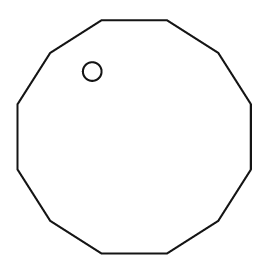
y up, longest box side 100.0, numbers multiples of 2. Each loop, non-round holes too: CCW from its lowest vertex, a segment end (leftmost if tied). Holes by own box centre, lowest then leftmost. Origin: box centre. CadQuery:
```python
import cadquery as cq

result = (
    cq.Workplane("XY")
    .moveTo(-14.0, -50.0)
    .lineTo(14.0, -50.0)
    .lineTo(36.0, -36.0)
    .lineTo(50.0, -14.0)
    .lineTo(50.0, 14.0)
    .lineTo(36.0, 36.0)
    .lineTo(14.0, 50.0)
    .lineTo(-14.0, 50.0)
    .lineTo(-36.0, 36.0)
    .lineTo(-50.0, 14.0)
    .lineTo(-50.0, -14.0)
    .lineTo(-36.0, -36.0)
    .close()
    .moveTo(-18.0, 28.0)
    .circle(4.0)
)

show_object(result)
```